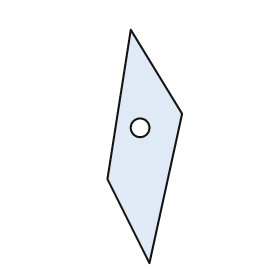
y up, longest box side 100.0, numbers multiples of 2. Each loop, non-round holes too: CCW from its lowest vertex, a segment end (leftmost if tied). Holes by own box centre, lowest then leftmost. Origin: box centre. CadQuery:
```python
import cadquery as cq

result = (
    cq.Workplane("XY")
    .moveTo(2.0, -50.0)
    .lineTo(16.0, 14.0)
    .lineTo(-6.0, 50.0)
    .lineTo(-16.0, -14.0)
    .close()
    .moveTo(-2.0, 8.0)
    .circle(4.0)
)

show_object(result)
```